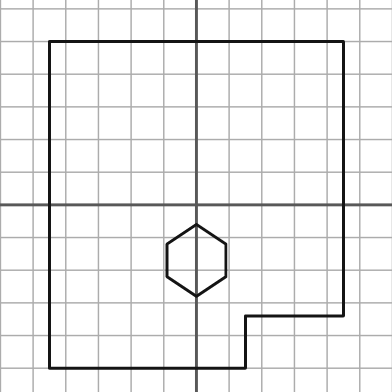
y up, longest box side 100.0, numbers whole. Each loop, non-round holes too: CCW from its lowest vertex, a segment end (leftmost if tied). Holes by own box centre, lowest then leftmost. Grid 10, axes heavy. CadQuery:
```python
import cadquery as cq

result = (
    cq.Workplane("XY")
    .moveTo(-45.0, -50.0)
    .lineTo(15.0, -50.0)
    .lineTo(15.0, -34.0)
    .lineTo(45.0, -34.0)
    .lineTo(45.0, 50.0)
    .lineTo(-45.0, 50.0)
    .close()
    .moveTo(0.0, -28.0)
    .lineTo(9.0, -22.0)
    .lineTo(9.0, -12.0)
    .lineTo(0.0, -6.0)
    .lineTo(-9.0, -12.0)
    .lineTo(-9.0, -22.0)
    .close()
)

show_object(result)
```